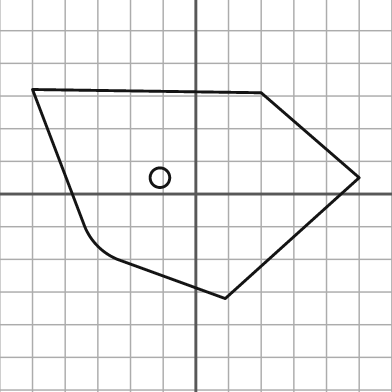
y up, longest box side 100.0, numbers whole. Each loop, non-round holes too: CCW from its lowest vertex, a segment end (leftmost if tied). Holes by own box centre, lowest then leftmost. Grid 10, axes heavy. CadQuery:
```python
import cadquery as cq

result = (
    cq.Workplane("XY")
    .moveTo(9.0, -32.0)
    .lineTo(50.0, 5.0)
    .lineTo(20.0, 31.0)
    .lineTo(-50.0, 32.0)
    .lineTo(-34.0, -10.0)
    .threePointArc((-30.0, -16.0), (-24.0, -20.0))
    .close()
    .moveTo(-11.0, 5.0)
    .circle(3.0)
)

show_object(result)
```